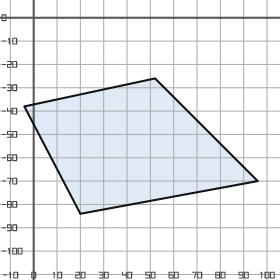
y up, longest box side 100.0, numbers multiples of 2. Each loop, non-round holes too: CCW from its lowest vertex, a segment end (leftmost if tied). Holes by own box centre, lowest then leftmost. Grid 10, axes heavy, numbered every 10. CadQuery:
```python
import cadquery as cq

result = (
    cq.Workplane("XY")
    .moveTo(20.0, -84.0)
    .lineTo(96.0, -70.0)
    .lineTo(52.0, -26.0)
    .lineTo(-4.0, -38.0)
    .close()
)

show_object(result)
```